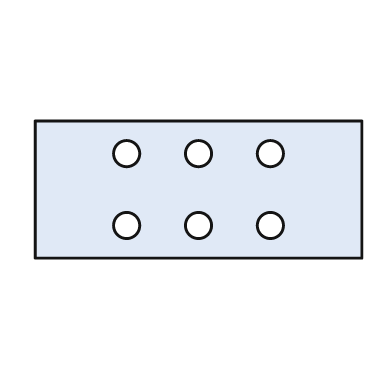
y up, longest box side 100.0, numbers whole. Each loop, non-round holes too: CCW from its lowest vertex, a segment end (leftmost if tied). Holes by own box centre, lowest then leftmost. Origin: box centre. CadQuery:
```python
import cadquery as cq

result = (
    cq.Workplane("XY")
    .moveTo(-50.0, -21.0)
    .lineTo(50.0, -21.0)
    .lineTo(50.0, 21.0)
    .lineTo(-50.0, 21.0)
    .close()
    .moveTo(-22.0, -11.0)
    .circle(4.0)
    .moveTo(0.0, -11.0)
    .circle(4.0)
    .moveTo(22.0, -11.0)
    .circle(4.0)
    .moveTo(-22.0, 11.0)
    .circle(4.0)
    .moveTo(0.0, 11.0)
    .circle(4.0)
    .moveTo(22.0, 11.0)
    .circle(4.0)
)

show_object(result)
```